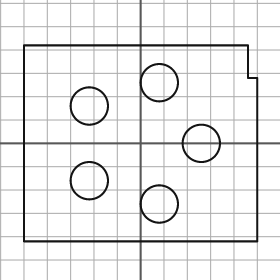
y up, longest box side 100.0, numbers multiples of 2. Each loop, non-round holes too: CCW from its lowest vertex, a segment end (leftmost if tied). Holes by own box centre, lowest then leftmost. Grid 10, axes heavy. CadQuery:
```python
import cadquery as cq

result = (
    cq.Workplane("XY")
    .moveTo(-50.0, -42.0)
    .lineTo(50.0, -42.0)
    .lineTo(50.0, 28.0)
    .lineTo(46.0, 28.0)
    .lineTo(46.0, 42.0)
    .lineTo(-50.0, 42.0)
    .close()
    .moveTo(8.0, -26.0)
    .circle(8.0)
    .moveTo(-22.0, -16.0)
    .circle(8.0)
    .moveTo(26.0, 0.0)
    .circle(8.0)
    .moveTo(-22.0, 16.0)
    .circle(8.0)
    .moveTo(8.0, 26.0)
    .circle(8.0)
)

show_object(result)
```